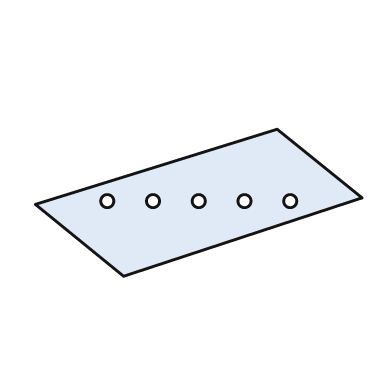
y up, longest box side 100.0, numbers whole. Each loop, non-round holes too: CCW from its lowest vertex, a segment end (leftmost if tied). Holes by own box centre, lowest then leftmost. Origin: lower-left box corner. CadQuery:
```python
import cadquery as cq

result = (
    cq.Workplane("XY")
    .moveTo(27.0, 0.0)
    .lineTo(100.0, 24.0)
    .lineTo(74.0, 45.0)
    .lineTo(0.0, 22.0)
    .close()
    .moveTo(22.0, 23.0)
    .circle(2.0)
    .moveTo(36.0, 23.0)
    .circle(2.0)
    .moveTo(50.0, 23.0)
    .circle(2.0)
    .moveTo(64.0, 23.0)
    .circle(2.0)
    .moveTo(78.0, 23.0)
    .circle(2.0)
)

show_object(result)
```